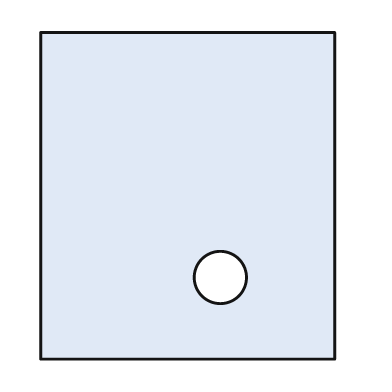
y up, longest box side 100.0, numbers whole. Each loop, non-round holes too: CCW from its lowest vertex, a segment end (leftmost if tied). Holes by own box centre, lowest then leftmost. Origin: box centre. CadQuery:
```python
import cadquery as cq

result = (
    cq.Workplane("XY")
    .moveTo(-45.0, -50.0)
    .lineTo(45.0, -50.0)
    .lineTo(45.0, 50.0)
    .lineTo(-45.0, 50.0)
    .close()
    .moveTo(10.0, -25.0)
    .circle(8.0)
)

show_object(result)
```